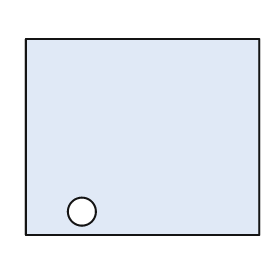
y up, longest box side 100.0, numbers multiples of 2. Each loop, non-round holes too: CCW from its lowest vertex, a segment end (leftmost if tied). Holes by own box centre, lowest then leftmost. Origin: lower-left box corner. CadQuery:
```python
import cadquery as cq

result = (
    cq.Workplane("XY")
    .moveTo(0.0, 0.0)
    .lineTo(100.0, 0.0)
    .lineTo(100.0, 84.0)
    .lineTo(0.0, 84.0)
    .close()
    .moveTo(24.0, 10.0)
    .circle(6.0)
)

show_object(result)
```